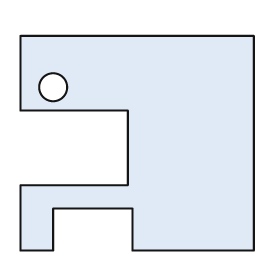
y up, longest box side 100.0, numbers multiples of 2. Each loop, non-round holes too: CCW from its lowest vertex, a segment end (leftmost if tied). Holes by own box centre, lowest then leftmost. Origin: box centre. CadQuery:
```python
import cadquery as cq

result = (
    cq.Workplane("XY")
    .moveTo(-50.0, -46.0)
    .lineTo(-36.0, -46.0)
    .lineTo(-36.0, -28.0)
    .lineTo(-2.0, -28.0)
    .lineTo(-2.0, -46.0)
    .lineTo(50.0, -46.0)
    .lineTo(50.0, 46.0)
    .lineTo(-50.0, 46.0)
    .lineTo(-50.0, 14.0)
    .lineTo(-4.0, 14.0)
    .lineTo(-4.0, -18.0)
    .lineTo(-50.0, -18.0)
    .close()
    .moveTo(-36.0, 24.0)
    .circle(6.0)
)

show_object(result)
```